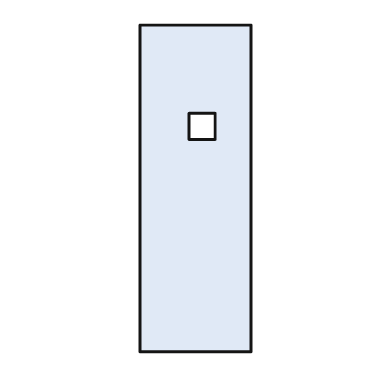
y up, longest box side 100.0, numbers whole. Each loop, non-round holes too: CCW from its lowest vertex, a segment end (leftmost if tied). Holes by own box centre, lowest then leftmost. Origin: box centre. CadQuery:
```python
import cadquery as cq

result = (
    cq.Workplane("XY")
    .moveTo(-17.0, -50.0)
    .lineTo(17.0, -50.0)
    .lineTo(17.0, 50.0)
    .lineTo(-17.0, 50.0)
    .close()
    .moveTo(-2.0, 15.0)
    .lineTo(6.0, 15.0)
    .lineTo(6.0, 23.0)
    .lineTo(-2.0, 23.0)
    .close()
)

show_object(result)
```